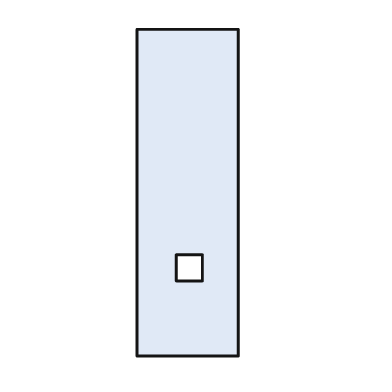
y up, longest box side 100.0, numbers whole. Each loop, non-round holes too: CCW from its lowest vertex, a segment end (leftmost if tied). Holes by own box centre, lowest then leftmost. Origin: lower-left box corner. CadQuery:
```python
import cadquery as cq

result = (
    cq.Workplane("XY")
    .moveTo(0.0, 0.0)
    .lineTo(31.0, 0.0)
    .lineTo(31.0, 100.0)
    .lineTo(0.0, 100.0)
    .close()
    .moveTo(12.0, 23.0)
    .lineTo(20.0, 23.0)
    .lineTo(20.0, 31.0)
    .lineTo(12.0, 31.0)
    .close()
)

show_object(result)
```